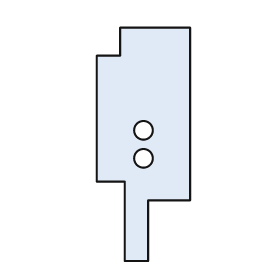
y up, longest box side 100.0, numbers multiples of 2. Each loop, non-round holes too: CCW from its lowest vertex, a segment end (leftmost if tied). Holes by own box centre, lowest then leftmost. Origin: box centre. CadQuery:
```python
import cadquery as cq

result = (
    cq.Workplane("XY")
    .moveTo(-8.0, -50.0)
    .lineTo(2.0, -50.0)
    .lineTo(2.0, -24.0)
    .lineTo(20.0, -24.0)
    .lineTo(20.0, 50.0)
    .lineTo(-10.0, 50.0)
    .lineTo(-10.0, 38.0)
    .lineTo(-20.0, 38.0)
    .lineTo(-20.0, -16.0)
    .lineTo(-8.0, -16.0)
    .close()
    .moveTo(0.0, -6.0)
    .circle(4.0)
    .moveTo(0.0, 6.0)
    .circle(4.0)
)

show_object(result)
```